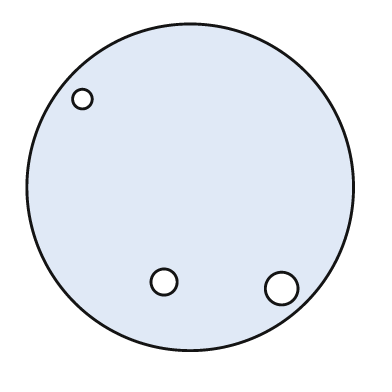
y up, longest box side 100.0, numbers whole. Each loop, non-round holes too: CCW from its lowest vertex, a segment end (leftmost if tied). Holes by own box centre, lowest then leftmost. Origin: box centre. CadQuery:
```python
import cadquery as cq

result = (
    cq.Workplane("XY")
    .moveTo(0.0, 0.0)
    .circle(50.0)
    .moveTo(28.0, -31.0)
    .circle(5.0)
    .moveTo(-8.0, -29.0)
    .circle(4.0)
    .moveTo(-33.0, 27.0)
    .circle(3.0)
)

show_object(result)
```